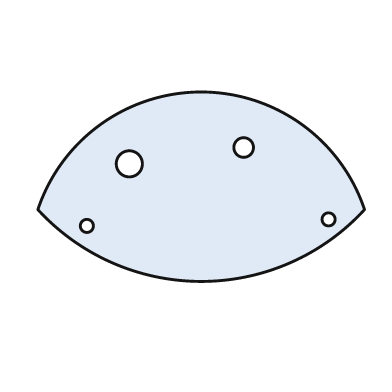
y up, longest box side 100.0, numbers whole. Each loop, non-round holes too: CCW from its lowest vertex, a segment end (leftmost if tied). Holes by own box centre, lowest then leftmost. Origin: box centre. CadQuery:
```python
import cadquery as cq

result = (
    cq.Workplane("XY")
    .moveTo(-50.0, -7.0)
    .threePointArc((0.0, -29.0), (50.0, -7.0))
    .threePointArc((0.0, 29.0), (-50.0, -7.0))
    .close()
    .moveTo(-35.0, -12.0)
    .circle(2.0)
    .moveTo(39.0, -10.0)
    .circle(2.0)
    .moveTo(-22.0, 7.0)
    .circle(4.0)
    .moveTo(13.0, 12.0)
    .circle(3.0)
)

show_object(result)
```